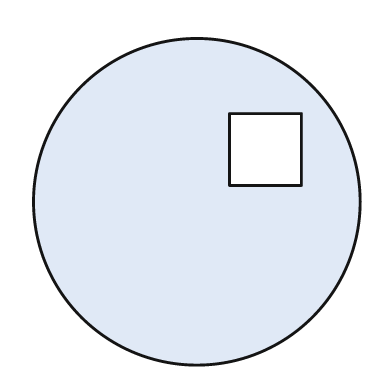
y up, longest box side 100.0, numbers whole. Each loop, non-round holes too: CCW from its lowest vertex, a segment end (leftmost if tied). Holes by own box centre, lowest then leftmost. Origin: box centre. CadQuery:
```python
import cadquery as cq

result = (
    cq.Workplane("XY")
    .moveTo(0.0, 0.0)
    .circle(50.0)
    .moveTo(10.0, 5.0)
    .lineTo(32.0, 5.0)
    .lineTo(32.0, 27.0)
    .lineTo(10.0, 27.0)
    .close()
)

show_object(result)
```